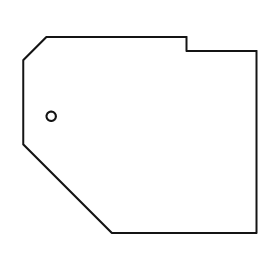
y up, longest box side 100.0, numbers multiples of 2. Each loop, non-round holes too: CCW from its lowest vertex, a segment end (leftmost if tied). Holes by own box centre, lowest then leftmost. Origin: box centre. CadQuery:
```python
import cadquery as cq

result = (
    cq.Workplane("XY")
    .moveTo(-12.0, -42.0)
    .lineTo(50.0, -42.0)
    .lineTo(50.0, 36.0)
    .lineTo(20.0, 36.0)
    .lineTo(20.0, 42.0)
    .lineTo(-40.0, 42.0)
    .lineTo(-50.0, 32.0)
    .lineTo(-50.0, -4.0)
    .close()
    .moveTo(-38.0, 8.0)
    .circle(2.0)
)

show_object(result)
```